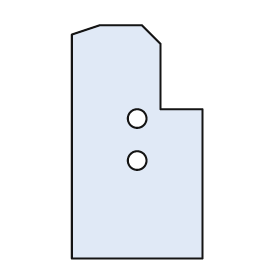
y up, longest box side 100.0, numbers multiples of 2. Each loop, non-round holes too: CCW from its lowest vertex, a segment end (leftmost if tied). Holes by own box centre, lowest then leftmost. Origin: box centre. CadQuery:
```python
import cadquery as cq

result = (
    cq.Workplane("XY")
    .moveTo(-28.0, -50.0)
    .lineTo(28.0, -50.0)
    .lineTo(28.0, 14.0)
    .lineTo(10.0, 14.0)
    .lineTo(10.0, 42.0)
    .lineTo(2.0, 50.0)
    .lineTo(-16.0, 50.0)
    .lineTo(-28.0, 46.0)
    .close()
    .moveTo(0.0, -8.0)
    .circle(4.0)
    .moveTo(0.0, 10.0)
    .circle(4.0)
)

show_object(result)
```